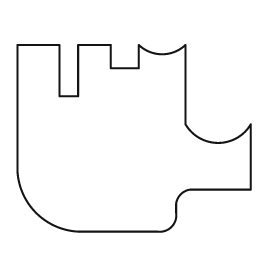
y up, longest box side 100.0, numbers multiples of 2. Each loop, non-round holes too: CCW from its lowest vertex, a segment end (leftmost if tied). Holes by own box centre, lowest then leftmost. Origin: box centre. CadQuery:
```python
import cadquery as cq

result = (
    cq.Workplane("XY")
    .moveTo(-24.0, -40.0)
    .lineTo(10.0, -40.0)
    .threePointArc((16.0, -38.0), (18.0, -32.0))
    .lineTo(18.0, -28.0)
    .threePointArc((20.0, -24.0), (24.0, -22.0))
    .lineTo(50.0, -22.0)
    .lineTo(50.0, 6.0)
    .threePointArc((36.0, -2.0), (22.0, 6.0))
    .lineTo(22.0, 40.0)
    .threePointArc((12.0, 36.0), (2.0, 40.0))
    .lineTo(2.0, 30.0)
    .lineTo(-10.0, 30.0)
    .lineTo(-10.0, 40.0)
    .lineTo(-24.0, 40.0)
    .lineTo(-24.0, 18.0)
    .lineTo(-32.0, 18.0)
    .lineTo(-32.0, 40.0)
    .lineTo(-50.0, 40.0)
    .lineTo(-50.0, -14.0)
    .threePointArc((-42.0, -32.0), (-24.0, -40.0))
    .close()
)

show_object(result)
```